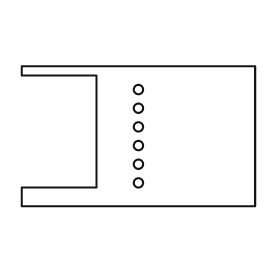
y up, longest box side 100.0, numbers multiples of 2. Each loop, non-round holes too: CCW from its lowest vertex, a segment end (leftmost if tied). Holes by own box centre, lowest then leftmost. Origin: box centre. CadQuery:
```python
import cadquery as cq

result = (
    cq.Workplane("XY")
    .moveTo(-50.0, -30.0)
    .lineTo(50.0, -30.0)
    .lineTo(50.0, 30.0)
    .lineTo(-50.0, 30.0)
    .lineTo(-50.0, 26.0)
    .lineTo(-18.0, 26.0)
    .lineTo(-18.0, -22.0)
    .lineTo(-50.0, -22.0)
    .close()
    .moveTo(0.0, -20.0)
    .circle(2.0)
    .moveTo(0.0, -12.0)
    .circle(2.0)
    .moveTo(0.0, -4.0)
    .circle(2.0)
    .moveTo(0.0, 4.0)
    .circle(2.0)
    .moveTo(0.0, 12.0)
    .circle(2.0)
    .moveTo(0.0, 20.0)
    .circle(2.0)
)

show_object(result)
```